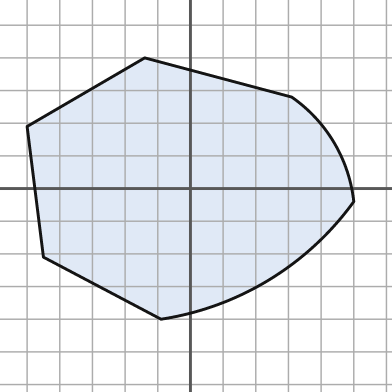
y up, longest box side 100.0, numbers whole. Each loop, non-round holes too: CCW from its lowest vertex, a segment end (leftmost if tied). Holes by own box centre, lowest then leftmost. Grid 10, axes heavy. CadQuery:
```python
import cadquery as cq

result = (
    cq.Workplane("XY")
    .moveTo(-9.0, -40.0)
    .threePointArc((24.0, -28.0), (50.0, -4.0))
    .threePointArc((44.0, 14.0), (31.0, 28.0))
    .lineTo(-14.0, 40.0)
    .lineTo(-50.0, 19.0)
    .lineTo(-45.0, -21.0)
    .close()
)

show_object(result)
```